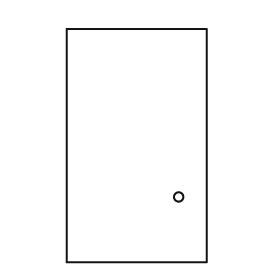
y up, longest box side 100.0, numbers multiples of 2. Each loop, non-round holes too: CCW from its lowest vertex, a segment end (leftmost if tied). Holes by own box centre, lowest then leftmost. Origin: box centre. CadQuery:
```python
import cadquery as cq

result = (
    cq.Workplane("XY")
    .moveTo(-30.0, -50.0)
    .lineTo(30.0, -50.0)
    .lineTo(30.0, 50.0)
    .lineTo(-30.0, 50.0)
    .close()
    .moveTo(18.0, -22.0)
    .circle(2.0)
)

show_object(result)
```